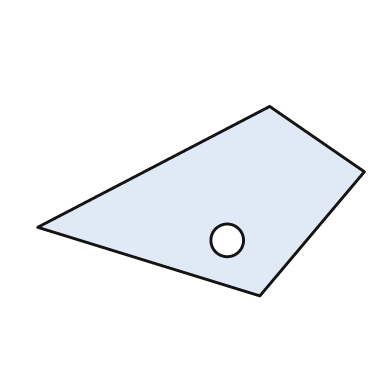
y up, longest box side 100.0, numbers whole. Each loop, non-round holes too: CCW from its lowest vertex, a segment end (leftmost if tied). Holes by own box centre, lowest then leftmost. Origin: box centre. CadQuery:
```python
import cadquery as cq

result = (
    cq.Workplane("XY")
    .moveTo(18.0, -29.0)
    .lineTo(50.0, 9.0)
    .lineTo(21.0, 29.0)
    .lineTo(-50.0, -8.0)
    .close()
    .moveTo(8.0, -12.0)
    .circle(5.0)
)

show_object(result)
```